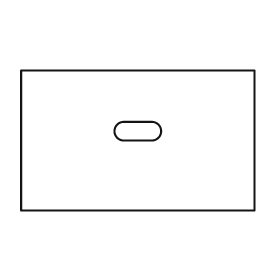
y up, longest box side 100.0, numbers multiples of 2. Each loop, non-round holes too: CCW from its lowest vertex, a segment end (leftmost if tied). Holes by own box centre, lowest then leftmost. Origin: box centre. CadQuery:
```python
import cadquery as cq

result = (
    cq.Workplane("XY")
    .moveTo(-50.0, -30.0)
    .lineTo(50.0, -30.0)
    .lineTo(50.0, 30.0)
    .lineTo(-50.0, 30.0)
    .close()
    .moveTo(-6.0, 0.0)
    .lineTo(6.0, 0.0)
    .threePointArc((10.0, 4.0), (6.0, 8.0))
    .lineTo(-6.0, 8.0)
    .threePointArc((-10.0, 4.0), (-6.0, 0.0))
    .close()
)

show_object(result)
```